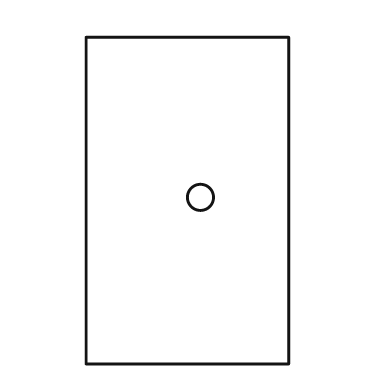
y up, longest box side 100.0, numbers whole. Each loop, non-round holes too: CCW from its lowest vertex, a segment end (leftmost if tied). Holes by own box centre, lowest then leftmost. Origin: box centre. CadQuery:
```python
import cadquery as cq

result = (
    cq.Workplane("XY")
    .moveTo(-31.0, -50.0)
    .lineTo(31.0, -50.0)
    .lineTo(31.0, 50.0)
    .lineTo(-31.0, 50.0)
    .close()
    .moveTo(4.0, 1.0)
    .circle(4.0)
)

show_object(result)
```